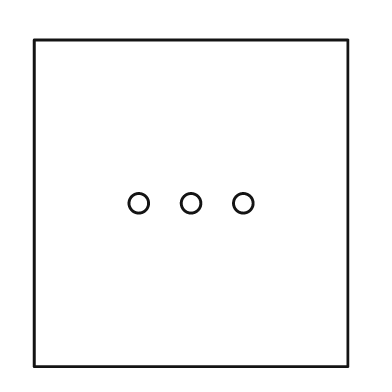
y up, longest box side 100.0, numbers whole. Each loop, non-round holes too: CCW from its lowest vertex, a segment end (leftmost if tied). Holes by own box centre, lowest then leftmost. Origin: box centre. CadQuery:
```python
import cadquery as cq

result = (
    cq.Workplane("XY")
    .moveTo(-48.0, -50.0)
    .lineTo(48.0, -50.0)
    .lineTo(48.0, 50.0)
    .lineTo(-48.0, 50.0)
    .close()
    .moveTo(-16.0, 0.0)
    .circle(3.0)
    .moveTo(0.0, 0.0)
    .circle(3.0)
    .moveTo(16.0, 0.0)
    .circle(3.0)
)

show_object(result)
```